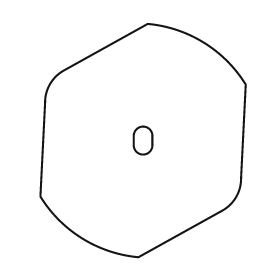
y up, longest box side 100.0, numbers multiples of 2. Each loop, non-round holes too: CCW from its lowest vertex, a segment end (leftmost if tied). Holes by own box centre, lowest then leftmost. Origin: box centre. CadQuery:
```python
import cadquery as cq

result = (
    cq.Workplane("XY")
    .moveTo(-2.0, -50.0)
    .lineTo(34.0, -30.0)
    .threePointArc((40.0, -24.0), (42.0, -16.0))
    .lineTo(44.0, 24.0)
    .threePointArc((26.0, 42.0), (2.0, 50.0))
    .lineTo(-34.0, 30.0)
    .threePointArc((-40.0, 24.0), (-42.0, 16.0))
    .lineTo(-44.0, -24.0)
    .threePointArc((-26.0, -42.0), (-2.0, -50.0))
    .close()
    .moveTo(-4.0, -2.0)
    .threePointArc((0.0, -6.0), (4.0, -2.0))
    .lineTo(4.0, 2.0)
    .threePointArc((0.0, 6.0), (-4.0, 2.0))
    .close()
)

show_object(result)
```